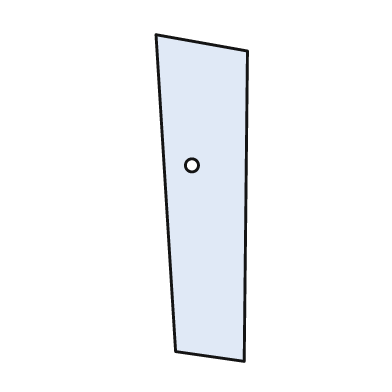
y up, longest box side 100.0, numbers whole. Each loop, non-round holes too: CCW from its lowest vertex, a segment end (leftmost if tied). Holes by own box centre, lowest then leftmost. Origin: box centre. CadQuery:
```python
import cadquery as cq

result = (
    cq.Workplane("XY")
    .moveTo(13.0, -50.0)
    .lineTo(14.0, 45.0)
    .lineTo(-14.0, 50.0)
    .lineTo(-8.0, -47.0)
    .close()
    .moveTo(-3.0, 10.0)
    .circle(2.0)
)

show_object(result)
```